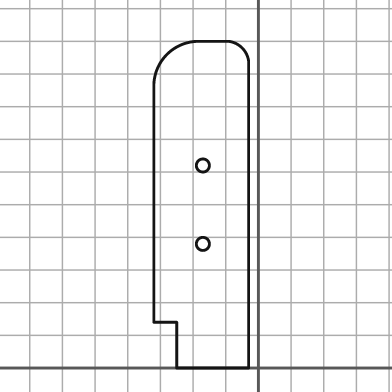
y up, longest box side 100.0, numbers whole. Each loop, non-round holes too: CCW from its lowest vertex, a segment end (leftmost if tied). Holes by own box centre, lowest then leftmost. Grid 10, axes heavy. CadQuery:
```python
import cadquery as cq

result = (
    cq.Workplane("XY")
    .moveTo(-25.0, 0.0)
    .lineTo(-3.0, 0.0)
    .lineTo(-3.0, 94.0)
    .threePointArc((-5.0, 98.0), (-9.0, 100.0))
    .lineTo(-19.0, 100.0)
    .threePointArc((-28.0, 96.0), (-32.0, 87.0))
    .lineTo(-32.0, 14.0)
    .lineTo(-25.0, 14.0)
    .close()
    .moveTo(-17.0, 38.0)
    .circle(2.0)
    .moveTo(-17.0, 62.0)
    .circle(2.0)
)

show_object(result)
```